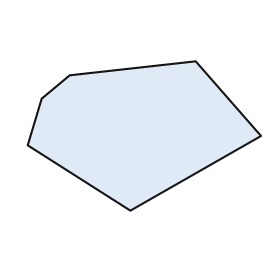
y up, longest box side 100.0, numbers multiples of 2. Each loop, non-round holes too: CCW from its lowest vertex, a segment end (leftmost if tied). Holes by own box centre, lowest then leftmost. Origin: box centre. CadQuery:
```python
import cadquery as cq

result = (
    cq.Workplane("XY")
    .moveTo(-6.0, -32.0)
    .lineTo(50.0, 0.0)
    .lineTo(22.0, 32.0)
    .lineTo(-32.0, 26.0)
    .lineTo(-44.0, 16.0)
    .lineTo(-50.0, -4.0)
    .close()
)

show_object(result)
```